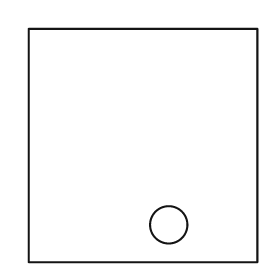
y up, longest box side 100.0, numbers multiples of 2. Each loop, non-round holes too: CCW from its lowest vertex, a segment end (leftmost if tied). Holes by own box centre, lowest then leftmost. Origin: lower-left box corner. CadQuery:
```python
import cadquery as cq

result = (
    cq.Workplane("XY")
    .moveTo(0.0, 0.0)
    .lineTo(98.0, 0.0)
    .lineTo(98.0, 100.0)
    .lineTo(0.0, 100.0)
    .close()
    .moveTo(60.0, 16.0)
    .circle(8.0)
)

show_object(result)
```